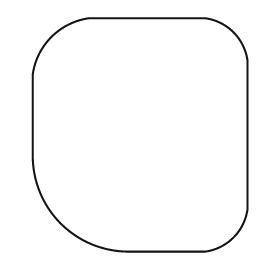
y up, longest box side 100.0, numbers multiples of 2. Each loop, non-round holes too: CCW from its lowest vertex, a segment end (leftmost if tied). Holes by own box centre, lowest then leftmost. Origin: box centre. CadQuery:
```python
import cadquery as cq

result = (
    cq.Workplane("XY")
    .moveTo(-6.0, -50.0)
    .lineTo(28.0, -50.0)
    .threePointArc((40.0, -44.0), (46.0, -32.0))
    .lineTo(46.0, 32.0)
    .threePointArc((40.0, 44.0), (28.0, 50.0))
    .lineTo(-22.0, 50.0)
    .threePointArc((-38.0, 42.0), (-46.0, 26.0))
    .lineTo(-46.0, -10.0)
    .threePointArc((-34.0, -38.0), (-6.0, -50.0))
    .close()
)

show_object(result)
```